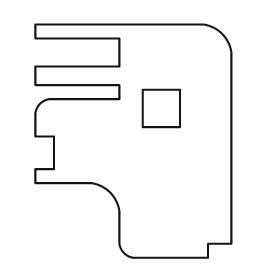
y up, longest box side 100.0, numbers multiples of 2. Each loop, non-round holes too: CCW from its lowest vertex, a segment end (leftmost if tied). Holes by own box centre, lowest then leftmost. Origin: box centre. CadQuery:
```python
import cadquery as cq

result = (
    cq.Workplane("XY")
    .moveTo(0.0, -50.0)
    .lineTo(32.0, -50.0)
    .lineTo(32.0, -44.0)
    .lineTo(42.0, -44.0)
    .lineTo(42.0, 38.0)
    .threePointArc((38.0, 46.0), (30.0, 50.0))
    .lineTo(-42.0, 50.0)
    .lineTo(-42.0, 44.0)
    .lineTo(-6.0, 44.0)
    .lineTo(-6.0, 32.0)
    .lineTo(-42.0, 32.0)
    .lineTo(-42.0, 24.0)
    .lineTo(-6.0, 24.0)
    .lineTo(-6.0, 18.0)
    .lineTo(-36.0, 18.0)
    .threePointArc((-40.0, 16.0), (-42.0, 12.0))
    .lineTo(-42.0, 2.0)
    .lineTo(-34.0, 2.0)
    .lineTo(-34.0, -12.0)
    .lineTo(-42.0, -12.0)
    .lineTo(-42.0, -18.0)
    .lineTo(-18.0, -18.0)
    .threePointArc((-10.0, -22.0), (-6.0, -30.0))
    .lineTo(-6.0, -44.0)
    .threePointArc((-4.0, -48.0), (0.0, -50.0))
    .close()
    .moveTo(4.0, 6.0)
    .lineTo(20.0, 6.0)
    .lineTo(20.0, 22.0)
    .lineTo(4.0, 22.0)
    .close()
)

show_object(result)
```